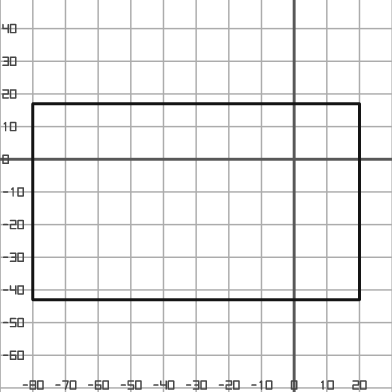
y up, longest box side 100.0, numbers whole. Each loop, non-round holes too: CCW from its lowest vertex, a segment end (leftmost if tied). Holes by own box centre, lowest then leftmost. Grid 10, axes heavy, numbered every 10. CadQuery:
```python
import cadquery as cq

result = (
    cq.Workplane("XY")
    .moveTo(-80.0, -43.0)
    .lineTo(20.0, -43.0)
    .lineTo(20.0, 17.0)
    .lineTo(-80.0, 17.0)
    .close()
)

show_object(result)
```